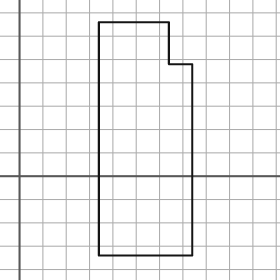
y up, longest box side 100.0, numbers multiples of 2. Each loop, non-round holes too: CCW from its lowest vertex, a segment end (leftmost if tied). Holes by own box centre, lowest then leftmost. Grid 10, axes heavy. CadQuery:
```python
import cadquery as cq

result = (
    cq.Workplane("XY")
    .moveTo(34.0, -34.0)
    .lineTo(74.0, -34.0)
    .lineTo(74.0, 48.0)
    .lineTo(64.0, 48.0)
    .lineTo(64.0, 66.0)
    .lineTo(34.0, 66.0)
    .close()
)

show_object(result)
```